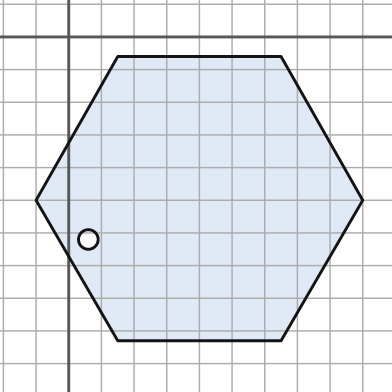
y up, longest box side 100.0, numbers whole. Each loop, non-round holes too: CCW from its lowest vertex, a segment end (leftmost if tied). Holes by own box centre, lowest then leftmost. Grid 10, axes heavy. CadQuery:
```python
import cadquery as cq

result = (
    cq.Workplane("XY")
    .moveTo(15.0, -93.0)
    .lineTo(65.0, -93.0)
    .lineTo(90.0, -50.0)
    .lineTo(65.0, -6.0)
    .lineTo(15.0, -6.0)
    .lineTo(-10.0, -50.0)
    .close()
    .moveTo(6.0, -62.0)
    .circle(3.0)
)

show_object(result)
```